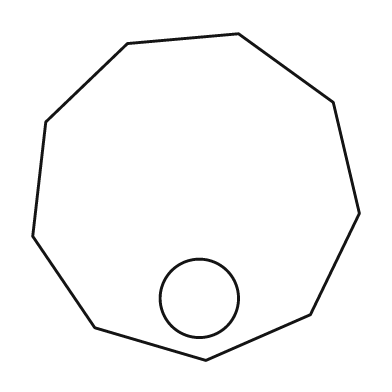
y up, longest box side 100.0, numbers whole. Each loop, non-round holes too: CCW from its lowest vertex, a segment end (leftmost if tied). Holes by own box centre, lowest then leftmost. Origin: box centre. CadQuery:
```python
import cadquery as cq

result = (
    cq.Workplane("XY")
    .moveTo(3.0, -50.0)
    .lineTo(35.0, -36.0)
    .lineTo(50.0, -5.0)
    .lineTo(42.0, 29.0)
    .lineTo(13.0, 50.0)
    .lineTo(-21.0, 47.0)
    .lineTo(-46.0, 23.0)
    .lineTo(-50.0, -12.0)
    .lineTo(-31.0, -40.0)
    .close()
    .moveTo(1.0, -31.0)
    .circle(12.0)
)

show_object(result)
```